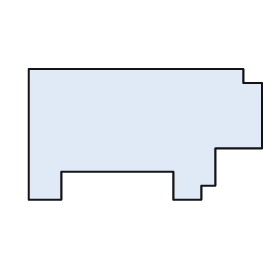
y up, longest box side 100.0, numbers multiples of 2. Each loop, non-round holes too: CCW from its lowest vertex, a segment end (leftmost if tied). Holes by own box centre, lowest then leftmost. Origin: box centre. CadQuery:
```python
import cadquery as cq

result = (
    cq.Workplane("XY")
    .moveTo(-50.0, -28.0)
    .lineTo(-36.0, -28.0)
    .lineTo(-36.0, -16.0)
    .lineTo(12.0, -16.0)
    .lineTo(12.0, -28.0)
    .lineTo(24.0, -28.0)
    .lineTo(24.0, -22.0)
    .lineTo(30.0, -22.0)
    .lineTo(30.0, -6.0)
    .lineTo(50.0, -6.0)
    .lineTo(50.0, 22.0)
    .lineTo(42.0, 22.0)
    .lineTo(42.0, 28.0)
    .lineTo(-50.0, 28.0)
    .close()
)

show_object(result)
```